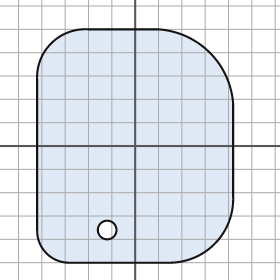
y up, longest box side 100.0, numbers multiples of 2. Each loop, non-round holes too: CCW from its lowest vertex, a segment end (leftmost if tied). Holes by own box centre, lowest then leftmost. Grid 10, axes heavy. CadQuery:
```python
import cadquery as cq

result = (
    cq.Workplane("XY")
    .moveTo(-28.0, -50.0)
    .lineTo(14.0, -50.0)
    .threePointArc((34.0, -42.0), (42.0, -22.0))
    .lineTo(42.0, 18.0)
    .threePointArc((32.0, 40.0), (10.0, 50.0))
    .lineTo(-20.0, 50.0)
    .threePointArc((-36.0, 44.0), (-42.0, 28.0))
    .lineTo(-42.0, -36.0)
    .threePointArc((-38.0, -46.0), (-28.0, -50.0))
    .close()
    .moveTo(-12.0, -36.0)
    .circle(4.0)
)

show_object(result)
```